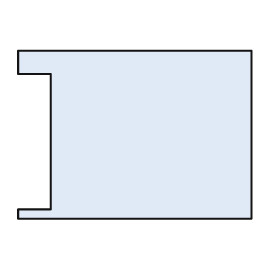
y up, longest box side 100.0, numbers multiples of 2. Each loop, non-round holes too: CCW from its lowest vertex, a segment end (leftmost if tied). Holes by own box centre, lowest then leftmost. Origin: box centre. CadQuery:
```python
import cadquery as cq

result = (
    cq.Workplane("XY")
    .moveTo(-50.0, -36.0)
    .lineTo(50.0, -36.0)
    .lineTo(50.0, 36.0)
    .lineTo(-50.0, 36.0)
    .lineTo(-50.0, 26.0)
    .lineTo(-36.0, 26.0)
    .lineTo(-36.0, -32.0)
    .lineTo(-50.0, -32.0)
    .close()
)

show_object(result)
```